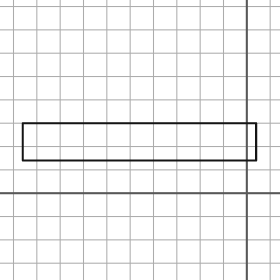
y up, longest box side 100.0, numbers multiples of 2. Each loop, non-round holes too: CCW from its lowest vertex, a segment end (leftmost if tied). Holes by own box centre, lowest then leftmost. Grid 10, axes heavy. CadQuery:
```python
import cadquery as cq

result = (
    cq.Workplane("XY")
    .moveTo(-96.0, 14.0)
    .lineTo(4.0, 14.0)
    .lineTo(4.0, 30.0)
    .lineTo(-96.0, 30.0)
    .close()
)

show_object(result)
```